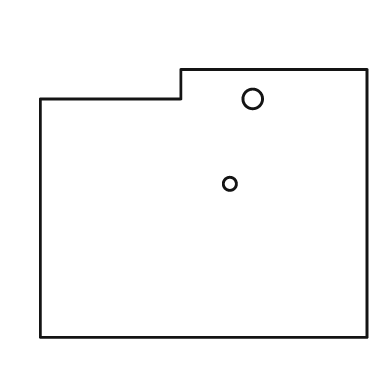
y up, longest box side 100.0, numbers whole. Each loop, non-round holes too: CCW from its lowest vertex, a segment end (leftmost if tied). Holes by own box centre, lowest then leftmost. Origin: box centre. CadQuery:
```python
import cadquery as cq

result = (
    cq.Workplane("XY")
    .moveTo(-50.0, -41.0)
    .lineTo(50.0, -41.0)
    .lineTo(50.0, 41.0)
    .lineTo(-7.0, 41.0)
    .lineTo(-7.0, 32.0)
    .lineTo(-50.0, 32.0)
    .close()
    .moveTo(8.0, 6.0)
    .circle(2.0)
    .moveTo(15.0, 32.0)
    .circle(3.0)
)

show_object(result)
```